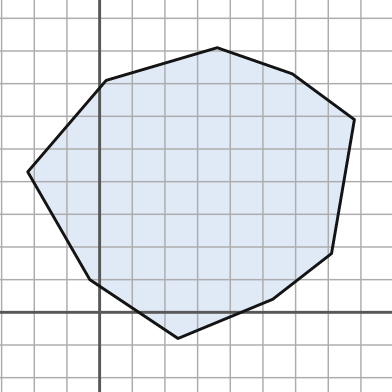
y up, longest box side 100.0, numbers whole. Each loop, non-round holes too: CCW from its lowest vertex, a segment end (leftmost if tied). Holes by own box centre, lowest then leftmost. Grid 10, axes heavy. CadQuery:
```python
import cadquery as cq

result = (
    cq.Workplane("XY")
    .moveTo(24.0, -8.0)
    .lineTo(53.0, 4.0)
    .lineTo(71.0, 18.0)
    .lineTo(78.0, 59.0)
    .lineTo(59.0, 73.0)
    .lineTo(36.0, 81.0)
    .lineTo(2.0, 71.0)
    .lineTo(-22.0, 43.0)
    .lineTo(-3.0, 10.0)
    .close()
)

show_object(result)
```